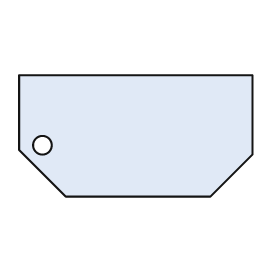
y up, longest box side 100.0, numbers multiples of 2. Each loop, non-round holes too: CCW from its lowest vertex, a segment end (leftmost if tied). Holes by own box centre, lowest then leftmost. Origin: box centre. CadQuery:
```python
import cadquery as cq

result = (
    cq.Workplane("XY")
    .moveTo(-30.0, -26.0)
    .lineTo(32.0, -26.0)
    .lineTo(50.0, -8.0)
    .lineTo(50.0, 26.0)
    .lineTo(-50.0, 26.0)
    .lineTo(-50.0, -6.0)
    .close()
    .moveTo(-40.0, -4.0)
    .circle(4.0)
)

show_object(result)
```